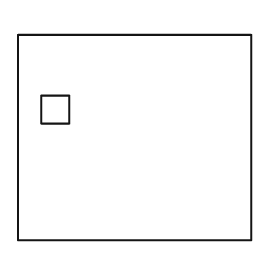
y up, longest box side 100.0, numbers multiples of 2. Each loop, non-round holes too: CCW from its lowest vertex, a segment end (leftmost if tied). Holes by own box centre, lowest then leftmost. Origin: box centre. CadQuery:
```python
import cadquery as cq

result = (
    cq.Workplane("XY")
    .moveTo(-50.0, -44.0)
    .lineTo(50.0, -44.0)
    .lineTo(50.0, 44.0)
    .lineTo(-50.0, 44.0)
    .close()
    .moveTo(-40.0, 6.0)
    .lineTo(-28.0, 6.0)
    .lineTo(-28.0, 18.0)
    .lineTo(-40.0, 18.0)
    .close()
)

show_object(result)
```